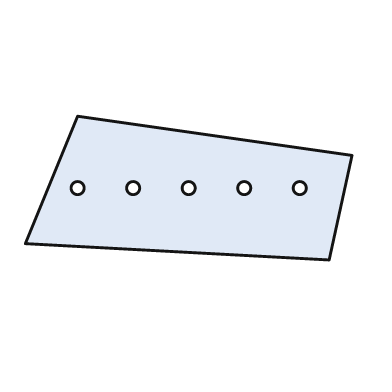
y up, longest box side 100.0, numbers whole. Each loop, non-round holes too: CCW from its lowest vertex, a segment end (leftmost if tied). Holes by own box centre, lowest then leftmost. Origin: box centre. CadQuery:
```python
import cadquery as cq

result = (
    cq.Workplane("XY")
    .moveTo(43.0, -22.0)
    .lineTo(50.0, 10.0)
    .lineTo(-34.0, 22.0)
    .lineTo(-50.0, -17.0)
    .close()
    .moveTo(-34.0, 0.0)
    .circle(2.0)
    .moveTo(-17.0, 0.0)
    .circle(2.0)
    .moveTo(0.0, 0.0)
    .circle(2.0)
    .moveTo(17.0, 0.0)
    .circle(2.0)
    .moveTo(34.0, 0.0)
    .circle(2.0)
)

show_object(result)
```